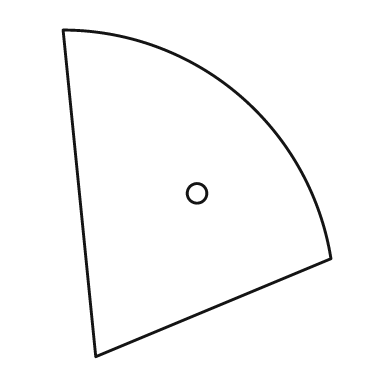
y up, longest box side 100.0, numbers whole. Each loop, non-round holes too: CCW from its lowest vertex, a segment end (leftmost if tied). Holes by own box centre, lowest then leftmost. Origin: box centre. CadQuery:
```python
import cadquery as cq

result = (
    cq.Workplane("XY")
    .moveTo(-31.0, -50.0)
    .lineTo(41.0, -20.0)
    .threePointArc((13.0, 30.0), (-41.0, 50.0))
    .close()
    .moveTo(0.0, 0.0)
    .circle(3.0)
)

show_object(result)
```